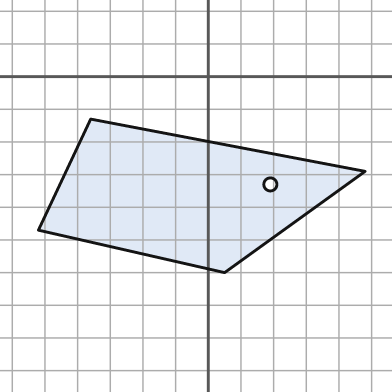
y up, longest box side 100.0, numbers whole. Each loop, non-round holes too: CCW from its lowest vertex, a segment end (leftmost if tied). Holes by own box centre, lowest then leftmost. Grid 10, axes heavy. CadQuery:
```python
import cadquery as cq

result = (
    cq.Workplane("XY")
    .moveTo(5.0, -60.0)
    .lineTo(48.0, -29.0)
    .lineTo(-36.0, -13.0)
    .lineTo(-52.0, -47.0)
    .close()
    .moveTo(19.0, -33.0)
    .circle(2.0)
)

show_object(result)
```